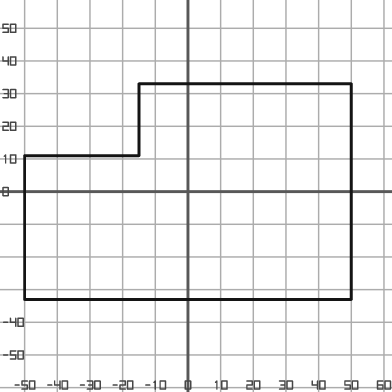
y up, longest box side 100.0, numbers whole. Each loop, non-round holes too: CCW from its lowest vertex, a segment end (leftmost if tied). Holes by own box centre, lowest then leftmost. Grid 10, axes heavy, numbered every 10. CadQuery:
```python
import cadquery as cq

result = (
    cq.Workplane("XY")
    .moveTo(-50.0, -33.0)
    .lineTo(50.0, -33.0)
    .lineTo(50.0, 33.0)
    .lineTo(-15.0, 33.0)
    .lineTo(-15.0, 11.0)
    .lineTo(-50.0, 11.0)
    .close()
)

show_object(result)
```